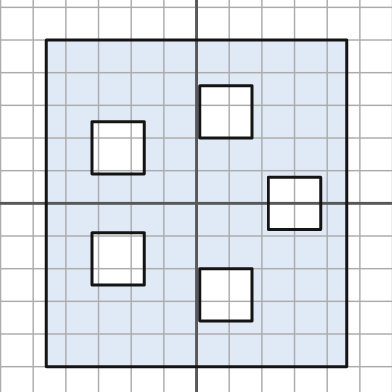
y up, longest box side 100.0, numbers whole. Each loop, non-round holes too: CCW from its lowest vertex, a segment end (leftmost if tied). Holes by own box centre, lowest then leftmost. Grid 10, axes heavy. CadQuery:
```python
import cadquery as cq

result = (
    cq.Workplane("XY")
    .moveTo(-46.0, -50.0)
    .lineTo(46.0, -50.0)
    .lineTo(46.0, 50.0)
    .lineTo(-46.0, 50.0)
    .close()
    .moveTo(1.0, -36.0)
    .lineTo(17.0, -36.0)
    .lineTo(17.0, -20.0)
    .lineTo(1.0, -20.0)
    .close()
    .moveTo(-32.0, -25.0)
    .lineTo(-16.0, -25.0)
    .lineTo(-16.0, -9.0)
    .lineTo(-32.0, -9.0)
    .close()
    .moveTo(22.0, -8.0)
    .lineTo(38.0, -8.0)
    .lineTo(38.0, 8.0)
    .lineTo(22.0, 8.0)
    .close()
    .moveTo(-32.0, 9.0)
    .lineTo(-16.0, 9.0)
    .lineTo(-16.0, 25.0)
    .lineTo(-32.0, 25.0)
    .close()
    .moveTo(1.0, 20.0)
    .lineTo(17.0, 20.0)
    .lineTo(17.0, 36.0)
    .lineTo(1.0, 36.0)
    .close()
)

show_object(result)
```